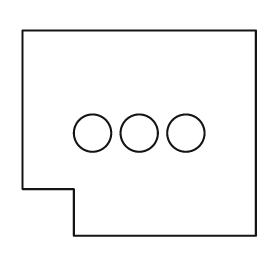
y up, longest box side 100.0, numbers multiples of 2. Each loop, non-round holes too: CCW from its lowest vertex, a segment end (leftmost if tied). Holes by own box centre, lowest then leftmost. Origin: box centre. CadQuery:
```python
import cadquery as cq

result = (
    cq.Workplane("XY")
    .moveTo(-28.0, -44.0)
    .lineTo(50.0, -44.0)
    .lineTo(50.0, 44.0)
    .lineTo(-50.0, 44.0)
    .lineTo(-50.0, -24.0)
    .lineTo(-28.0, -24.0)
    .close()
    .moveTo(-20.0, 0.0)
    .circle(8.0)
    .moveTo(0.0, 0.0)
    .circle(8.0)
    .moveTo(20.0, 0.0)
    .circle(8.0)
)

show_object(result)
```